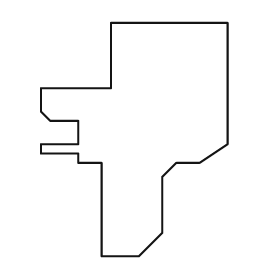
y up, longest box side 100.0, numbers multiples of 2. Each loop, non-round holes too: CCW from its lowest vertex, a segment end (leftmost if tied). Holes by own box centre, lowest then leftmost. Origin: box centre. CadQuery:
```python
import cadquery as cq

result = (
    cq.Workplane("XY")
    .moveTo(-14.0, -50.0)
    .lineTo(2.0, -50.0)
    .lineTo(12.0, -40.0)
    .lineTo(12.0, -16.0)
    .lineTo(18.0, -10.0)
    .lineTo(28.0, -10.0)
    .lineTo(40.0, -2.0)
    .lineTo(40.0, 50.0)
    .lineTo(-10.0, 50.0)
    .lineTo(-10.0, 22.0)
    .lineTo(-40.0, 22.0)
    .lineTo(-40.0, 12.0)
    .lineTo(-36.0, 8.0)
    .lineTo(-24.0, 8.0)
    .lineTo(-24.0, -2.0)
    .lineTo(-40.0, -2.0)
    .lineTo(-40.0, -6.0)
    .lineTo(-24.0, -6.0)
    .lineTo(-24.0, -10.0)
    .lineTo(-14.0, -10.0)
    .close()
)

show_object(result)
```